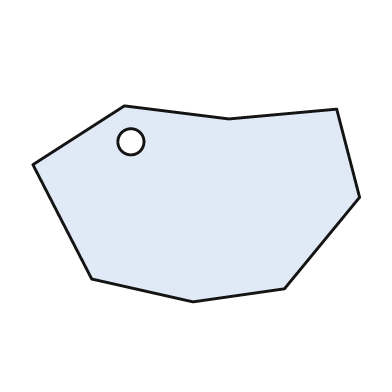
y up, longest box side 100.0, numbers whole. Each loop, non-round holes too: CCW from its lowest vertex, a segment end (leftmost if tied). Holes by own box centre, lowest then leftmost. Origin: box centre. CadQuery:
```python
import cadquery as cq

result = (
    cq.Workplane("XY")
    .moveTo(-1.0, -30.0)
    .lineTo(27.0, -26.0)
    .lineTo(50.0, 2.0)
    .lineTo(43.0, 29.0)
    .lineTo(10.0, 26.0)
    .lineTo(-22.0, 30.0)
    .lineTo(-50.0, 12.0)
    .lineTo(-32.0, -23.0)
    .close()
    .moveTo(-20.0, 19.0)
    .circle(4.0)
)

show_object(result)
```